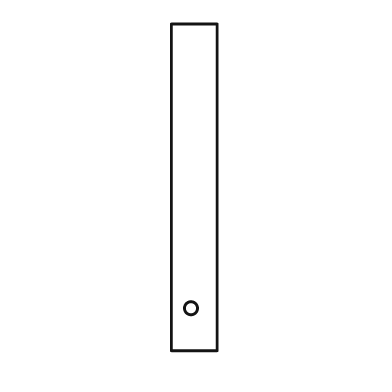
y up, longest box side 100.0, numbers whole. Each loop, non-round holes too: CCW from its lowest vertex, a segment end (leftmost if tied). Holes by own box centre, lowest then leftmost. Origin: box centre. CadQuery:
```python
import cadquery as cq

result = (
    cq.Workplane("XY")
    .moveTo(-7.0, -50.0)
    .lineTo(7.0, -50.0)
    .lineTo(7.0, 50.0)
    .lineTo(-7.0, 50.0)
    .close()
    .moveTo(-1.0, -37.0)
    .circle(2.0)
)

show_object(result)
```